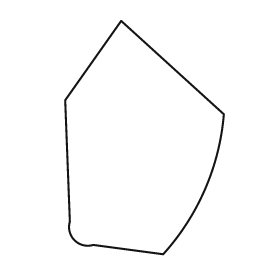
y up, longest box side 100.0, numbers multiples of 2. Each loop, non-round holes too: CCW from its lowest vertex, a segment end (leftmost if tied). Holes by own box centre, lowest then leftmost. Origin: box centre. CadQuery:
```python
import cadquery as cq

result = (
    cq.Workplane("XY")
    .moveTo(8.0, -50.0)
    .threePointArc((26.0, -22.0), (34.0, 10.0))
    .lineTo(-10.0, 50.0)
    .lineTo(-34.0, 16.0)
    .lineTo(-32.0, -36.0)
    .threePointArc((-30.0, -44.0), (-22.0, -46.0))
    .close()
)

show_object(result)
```